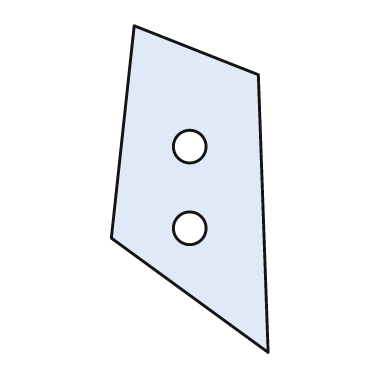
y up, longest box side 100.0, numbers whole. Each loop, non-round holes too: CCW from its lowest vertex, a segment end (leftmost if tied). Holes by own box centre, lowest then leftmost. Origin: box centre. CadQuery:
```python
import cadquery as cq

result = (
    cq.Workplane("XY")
    .moveTo(24.0, -50.0)
    .lineTo(21.0, 35.0)
    .lineTo(-17.0, 50.0)
    .lineTo(-24.0, -15.0)
    .close()
    .moveTo(0.0, -12.0)
    .circle(5.0)
    .moveTo(0.0, 13.0)
    .circle(5.0)
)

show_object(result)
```